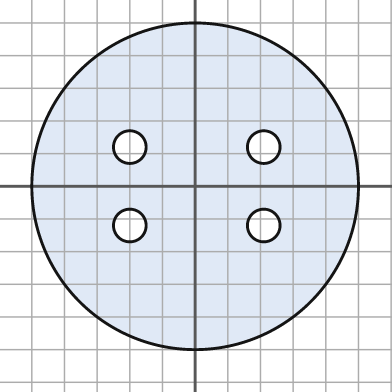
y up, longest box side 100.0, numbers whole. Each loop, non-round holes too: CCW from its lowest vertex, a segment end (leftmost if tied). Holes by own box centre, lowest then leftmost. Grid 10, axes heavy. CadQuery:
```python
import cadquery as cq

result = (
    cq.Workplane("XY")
    .moveTo(0.0, 0.0)
    .circle(50.0)
    .moveTo(-20.0, -12.0)
    .circle(5.0)
    .moveTo(21.0, -12.0)
    .circle(5.0)
    .moveTo(-20.0, 12.0)
    .circle(5.0)
    .moveTo(21.0, 12.0)
    .circle(5.0)
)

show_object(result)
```